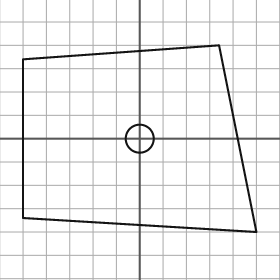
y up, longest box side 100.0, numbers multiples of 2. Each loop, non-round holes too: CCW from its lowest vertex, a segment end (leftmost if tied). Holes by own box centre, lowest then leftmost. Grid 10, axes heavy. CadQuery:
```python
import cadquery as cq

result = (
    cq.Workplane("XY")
    .moveTo(50.0, -40.0)
    .lineTo(34.0, 40.0)
    .lineTo(-50.0, 34.0)
    .lineTo(-50.0, -34.0)
    .close()
    .moveTo(0.0, 0.0)
    .circle(6.0)
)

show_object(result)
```